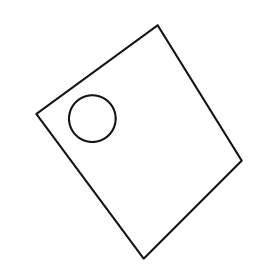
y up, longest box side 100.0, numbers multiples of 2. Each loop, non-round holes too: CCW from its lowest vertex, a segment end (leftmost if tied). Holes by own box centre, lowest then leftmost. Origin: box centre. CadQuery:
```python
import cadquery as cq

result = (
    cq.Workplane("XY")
    .moveTo(2.0, -50.0)
    .lineTo(44.0, -8.0)
    .lineTo(8.0, 50.0)
    .lineTo(-44.0, 12.0)
    .close()
    .moveTo(-20.0, 10.0)
    .circle(10.0)
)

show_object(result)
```